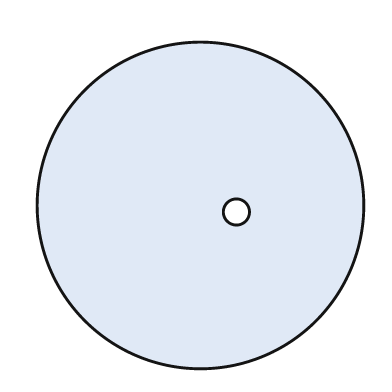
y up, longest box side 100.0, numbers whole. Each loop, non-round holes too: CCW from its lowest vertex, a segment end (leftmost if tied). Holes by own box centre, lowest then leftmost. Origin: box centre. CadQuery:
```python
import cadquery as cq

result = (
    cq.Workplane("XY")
    .moveTo(0.0, 0.0)
    .circle(50.0)
    .moveTo(11.0, -2.0)
    .circle(4.0)
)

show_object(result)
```